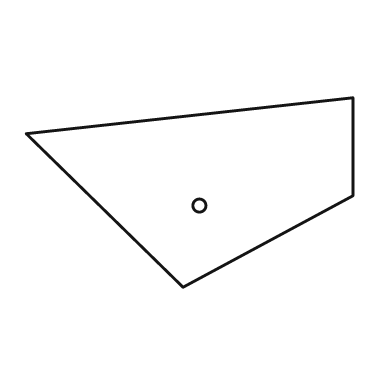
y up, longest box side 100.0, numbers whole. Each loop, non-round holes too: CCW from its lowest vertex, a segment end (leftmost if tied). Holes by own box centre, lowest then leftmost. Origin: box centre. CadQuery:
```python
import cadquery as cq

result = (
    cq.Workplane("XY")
    .moveTo(-2.0, -29.0)
    .lineTo(50.0, -1.0)
    .lineTo(50.0, 29.0)
    .lineTo(-50.0, 18.0)
    .close()
    .moveTo(3.0, -4.0)
    .circle(2.0)
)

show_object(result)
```